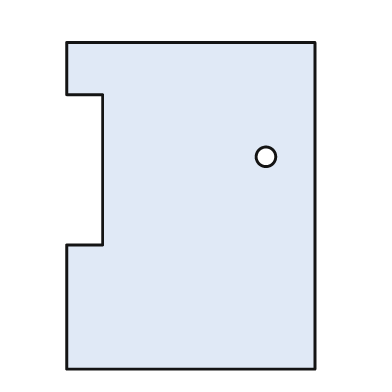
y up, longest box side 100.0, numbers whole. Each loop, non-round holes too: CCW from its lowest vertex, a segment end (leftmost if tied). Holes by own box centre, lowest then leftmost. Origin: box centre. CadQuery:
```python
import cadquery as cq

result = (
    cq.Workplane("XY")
    .moveTo(-38.0, -50.0)
    .lineTo(38.0, -50.0)
    .lineTo(38.0, 50.0)
    .lineTo(-38.0, 50.0)
    .lineTo(-38.0, 34.0)
    .lineTo(-27.0, 34.0)
    .lineTo(-27.0, -12.0)
    .lineTo(-38.0, -12.0)
    .close()
    .moveTo(23.0, 15.0)
    .circle(3.0)
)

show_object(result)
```